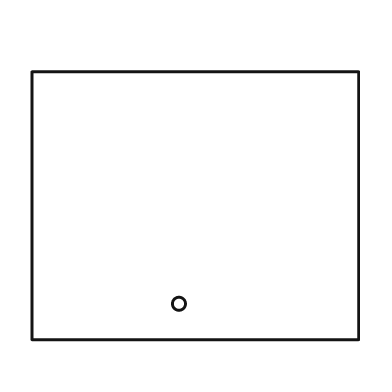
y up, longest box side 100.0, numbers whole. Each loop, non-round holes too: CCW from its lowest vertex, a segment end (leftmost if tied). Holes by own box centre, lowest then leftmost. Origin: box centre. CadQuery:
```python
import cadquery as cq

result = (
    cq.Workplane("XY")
    .moveTo(-50.0, -41.0)
    .lineTo(50.0, -41.0)
    .lineTo(50.0, 41.0)
    .lineTo(-50.0, 41.0)
    .close()
    .moveTo(-5.0, -30.0)
    .circle(2.0)
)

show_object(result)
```